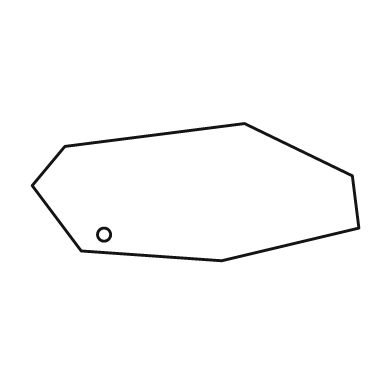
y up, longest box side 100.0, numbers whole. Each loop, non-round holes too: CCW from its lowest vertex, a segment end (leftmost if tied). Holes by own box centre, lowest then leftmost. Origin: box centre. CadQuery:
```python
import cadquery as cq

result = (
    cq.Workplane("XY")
    .moveTo(8.0, -21.0)
    .lineTo(50.0, -11.0)
    .lineTo(48.0, 5.0)
    .lineTo(15.0, 21.0)
    .lineTo(-40.0, 14.0)
    .lineTo(-50.0, 2.0)
    .lineTo(-35.0, -18.0)
    .close()
    .moveTo(-28.0, -13.0)
    .circle(2.0)
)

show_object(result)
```